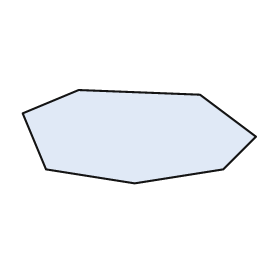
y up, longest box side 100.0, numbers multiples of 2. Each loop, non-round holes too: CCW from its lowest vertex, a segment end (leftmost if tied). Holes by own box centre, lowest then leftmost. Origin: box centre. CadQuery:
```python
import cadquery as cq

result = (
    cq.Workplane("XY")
    .moveTo(-2.0, -20.0)
    .lineTo(36.0, -14.0)
    .lineTo(50.0, 0.0)
    .lineTo(26.0, 18.0)
    .lineTo(-26.0, 20.0)
    .lineTo(-50.0, 10.0)
    .lineTo(-40.0, -14.0)
    .close()
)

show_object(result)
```